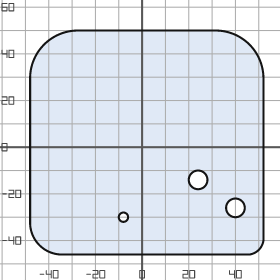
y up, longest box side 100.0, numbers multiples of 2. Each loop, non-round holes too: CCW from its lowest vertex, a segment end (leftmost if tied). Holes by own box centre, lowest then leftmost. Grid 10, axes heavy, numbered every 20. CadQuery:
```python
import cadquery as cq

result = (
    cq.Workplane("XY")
    .moveTo(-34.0, -46.0)
    .lineTo(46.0, -46.0)
    .threePointArc((50.0, -44.0), (52.0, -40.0))
    .lineTo(52.0, 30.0)
    .threePointArc((46.0, 44.0), (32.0, 50.0))
    .lineTo(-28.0, 50.0)
    .threePointArc((-42.0, 44.0), (-48.0, 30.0))
    .lineTo(-48.0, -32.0)
    .threePointArc((-44.0, -42.0), (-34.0, -46.0))
    .close()
    .moveTo(-8.0, -30.0)
    .circle(2.0)
    .moveTo(40.0, -26.0)
    .circle(4.0)
    .moveTo(24.0, -14.0)
    .circle(4.0)
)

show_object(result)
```